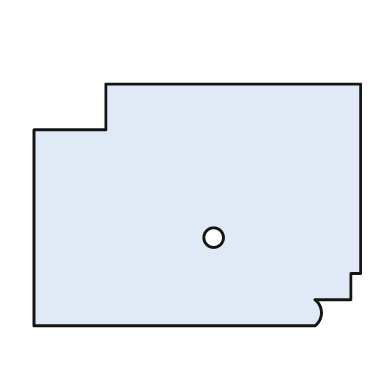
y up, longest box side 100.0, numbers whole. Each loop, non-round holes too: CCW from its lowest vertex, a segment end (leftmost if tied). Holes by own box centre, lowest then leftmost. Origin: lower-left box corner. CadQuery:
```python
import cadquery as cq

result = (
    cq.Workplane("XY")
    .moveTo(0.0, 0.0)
    .lineTo(86.0, 0.0)
    .threePointArc((88.0, 4.0), (86.0, 8.0))
    .lineTo(97.0, 8.0)
    .lineTo(97.0, 16.0)
    .lineTo(100.0, 16.0)
    .lineTo(100.0, 74.0)
    .lineTo(22.0, 74.0)
    .lineTo(22.0, 60.0)
    .lineTo(0.0, 60.0)
    .close()
    .moveTo(55.0, 27.0)
    .circle(3.0)
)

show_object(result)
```